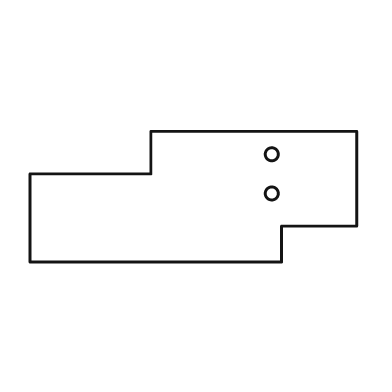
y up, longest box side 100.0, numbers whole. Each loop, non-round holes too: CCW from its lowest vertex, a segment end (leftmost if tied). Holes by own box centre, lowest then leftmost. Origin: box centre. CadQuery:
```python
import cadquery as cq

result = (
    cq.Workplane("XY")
    .moveTo(-50.0, -20.0)
    .lineTo(27.0, -20.0)
    .lineTo(27.0, -9.0)
    .lineTo(50.0, -9.0)
    .lineTo(50.0, 20.0)
    .lineTo(-13.0, 20.0)
    .lineTo(-13.0, 7.0)
    .lineTo(-50.0, 7.0)
    .close()
    .moveTo(24.0, 1.0)
    .circle(2.0)
    .moveTo(24.0, 13.0)
    .circle(2.0)
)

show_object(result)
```